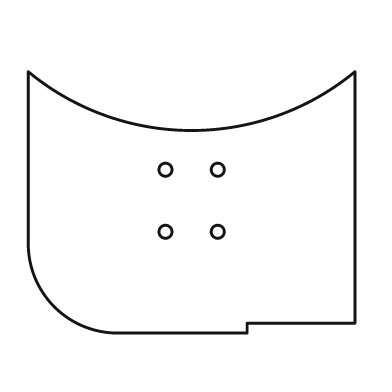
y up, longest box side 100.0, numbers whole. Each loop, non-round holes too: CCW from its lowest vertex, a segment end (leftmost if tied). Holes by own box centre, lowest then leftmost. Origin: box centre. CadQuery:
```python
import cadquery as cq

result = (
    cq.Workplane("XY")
    .moveTo(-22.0, -40.0)
    .lineTo(17.0, -40.0)
    .lineTo(17.0, -37.0)
    .lineTo(50.0, -37.0)
    .lineTo(50.0, 40.0)
    .threePointArc((0.0, 22.0), (-50.0, 40.0))
    .lineTo(-50.0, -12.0)
    .threePointArc((-42.0, -32.0), (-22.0, -40.0))
    .close()
    .moveTo(-8.0, -9.0)
    .circle(2.0)
    .moveTo(8.0, -9.0)
    .circle(2.0)
    .moveTo(-8.0, 10.0)
    .circle(2.0)
    .moveTo(8.0, 10.0)
    .circle(2.0)
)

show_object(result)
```